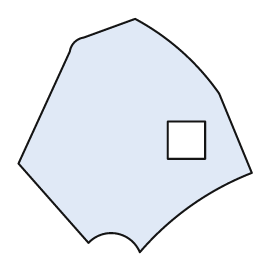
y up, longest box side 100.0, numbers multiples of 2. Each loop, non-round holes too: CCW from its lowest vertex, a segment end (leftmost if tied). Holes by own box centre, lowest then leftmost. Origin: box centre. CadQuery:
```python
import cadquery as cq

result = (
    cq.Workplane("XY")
    .moveTo(2.0, -50.0)
    .threePointArc((24.0, -30.0), (50.0, -16.0))
    .lineTo(36.0, 18.0)
    .threePointArc((20.0, 36.0), (0.0, 50.0))
    .lineTo(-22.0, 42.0)
    .threePointArc((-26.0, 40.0), (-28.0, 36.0))
    .lineTo(-50.0, -12.0)
    .lineTo(-20.0, -46.0)
    .threePointArc((-8.0, -42.0), (2.0, -50.0))
    .close()
    .moveTo(14.0, -10.0)
    .lineTo(30.0, -10.0)
    .lineTo(30.0, 6.0)
    .lineTo(14.0, 6.0)
    .close()
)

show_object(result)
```